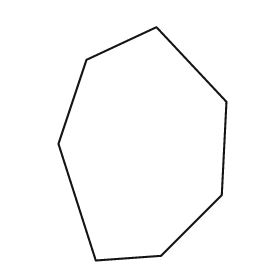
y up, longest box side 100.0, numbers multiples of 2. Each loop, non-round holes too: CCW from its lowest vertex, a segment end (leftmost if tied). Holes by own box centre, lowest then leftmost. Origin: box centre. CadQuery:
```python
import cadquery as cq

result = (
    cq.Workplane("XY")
    .moveTo(-20.0, -50.0)
    .lineTo(8.0, -48.0)
    .lineTo(34.0, -22.0)
    .lineTo(36.0, 18.0)
    .lineTo(6.0, 50.0)
    .lineTo(-24.0, 36.0)
    .lineTo(-36.0, 0.0)
    .close()
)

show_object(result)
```